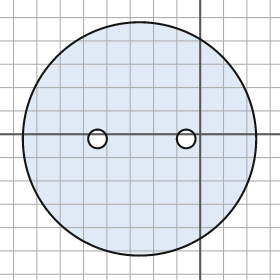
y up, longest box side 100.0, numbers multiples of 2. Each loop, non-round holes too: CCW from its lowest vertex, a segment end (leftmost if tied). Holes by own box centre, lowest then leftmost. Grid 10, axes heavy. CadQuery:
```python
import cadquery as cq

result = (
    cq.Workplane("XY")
    .moveTo(-26.0, -2.0)
    .circle(50.0)
    .moveTo(-44.0, -2.0)
    .circle(4.0)
    .moveTo(-6.0, -2.0)
    .circle(4.0)
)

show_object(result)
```